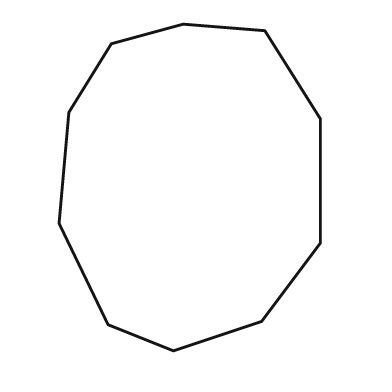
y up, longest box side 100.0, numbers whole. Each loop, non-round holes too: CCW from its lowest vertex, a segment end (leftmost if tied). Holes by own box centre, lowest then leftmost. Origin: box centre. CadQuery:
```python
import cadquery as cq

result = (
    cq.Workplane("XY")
    .moveTo(-5.0, -50.0)
    .lineTo(22.0, -41.0)
    .lineTo(40.0, -17.0)
    .lineTo(40.0, 21.0)
    .lineTo(23.0, 48.0)
    .lineTo(-2.0, 50.0)
    .lineTo(-24.0, 44.0)
    .lineTo(-37.0, 23.0)
    .lineTo(-40.0, -11.0)
    .lineTo(-25.0, -42.0)
    .close()
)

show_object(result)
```